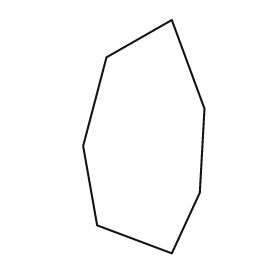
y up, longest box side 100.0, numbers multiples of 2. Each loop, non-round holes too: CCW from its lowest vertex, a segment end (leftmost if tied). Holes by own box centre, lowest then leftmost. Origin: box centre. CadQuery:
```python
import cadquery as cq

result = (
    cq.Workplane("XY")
    .moveTo(12.0, -50.0)
    .lineTo(24.0, -24.0)
    .lineTo(26.0, 12.0)
    .lineTo(12.0, 50.0)
    .lineTo(-16.0, 34.0)
    .lineTo(-26.0, -4.0)
    .lineTo(-20.0, -38.0)
    .close()
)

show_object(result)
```